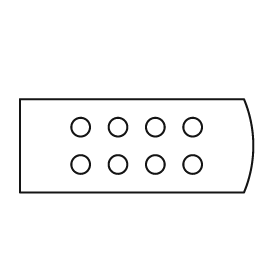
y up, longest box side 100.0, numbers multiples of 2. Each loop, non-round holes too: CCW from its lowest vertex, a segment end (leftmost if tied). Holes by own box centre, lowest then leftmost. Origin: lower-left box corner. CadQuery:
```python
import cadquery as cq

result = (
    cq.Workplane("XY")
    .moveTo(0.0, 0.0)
    .lineTo(96.0, 0.0)
    .threePointArc((100.0, 20.0), (96.0, 40.0))
    .lineTo(0.0, 40.0)
    .close()
    .moveTo(26.0, 12.0)
    .circle(4.0)
    .moveTo(42.0, 12.0)
    .circle(4.0)
    .moveTo(58.0, 12.0)
    .circle(4.0)
    .moveTo(74.0, 12.0)
    .circle(4.0)
    .moveTo(26.0, 28.0)
    .circle(4.0)
    .moveTo(42.0, 28.0)
    .circle(4.0)
    .moveTo(58.0, 28.0)
    .circle(4.0)
    .moveTo(74.0, 28.0)
    .circle(4.0)
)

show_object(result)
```